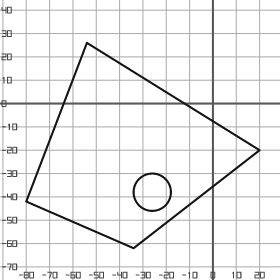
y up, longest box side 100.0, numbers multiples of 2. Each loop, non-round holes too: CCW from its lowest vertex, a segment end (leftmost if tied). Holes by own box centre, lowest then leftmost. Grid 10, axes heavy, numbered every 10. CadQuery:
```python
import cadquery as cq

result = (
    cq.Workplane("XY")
    .moveTo(-34.0, -62.0)
    .lineTo(20.0, -20.0)
    .lineTo(-54.0, 26.0)
    .lineTo(-80.0, -42.0)
    .close()
    .moveTo(-26.0, -38.0)
    .circle(8.0)
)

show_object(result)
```